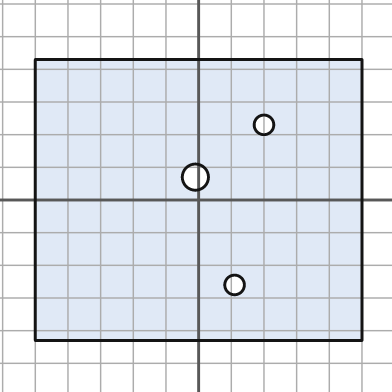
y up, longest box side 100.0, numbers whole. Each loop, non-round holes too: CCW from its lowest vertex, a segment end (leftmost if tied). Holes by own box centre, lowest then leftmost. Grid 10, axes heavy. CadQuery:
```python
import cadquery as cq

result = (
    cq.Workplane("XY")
    .moveTo(-50.0, -43.0)
    .lineTo(50.0, -43.0)
    .lineTo(50.0, 43.0)
    .lineTo(-50.0, 43.0)
    .close()
    .moveTo(11.0, -26.0)
    .circle(3.0)
    .moveTo(-1.0, 7.0)
    .circle(4.0)
    .moveTo(20.0, 23.0)
    .circle(3.0)
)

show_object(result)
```